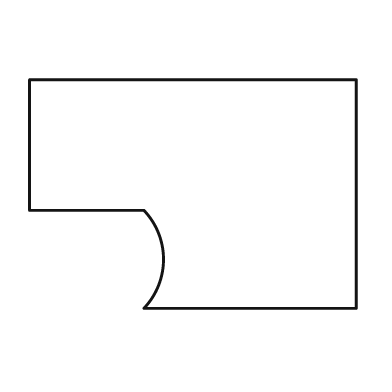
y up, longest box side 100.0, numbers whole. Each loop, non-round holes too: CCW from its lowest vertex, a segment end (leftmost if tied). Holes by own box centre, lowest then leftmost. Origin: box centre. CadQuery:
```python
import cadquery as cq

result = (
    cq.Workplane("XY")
    .moveTo(-15.0, -35.0)
    .lineTo(50.0, -35.0)
    .lineTo(50.0, 35.0)
    .lineTo(-50.0, 35.0)
    .lineTo(-50.0, -5.0)
    .lineTo(-15.0, -5.0)
    .threePointArc((-9.0, -20.0), (-15.0, -35.0))
    .close()
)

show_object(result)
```